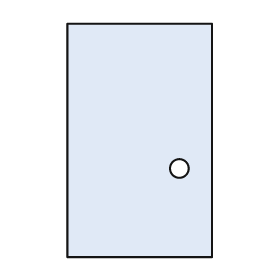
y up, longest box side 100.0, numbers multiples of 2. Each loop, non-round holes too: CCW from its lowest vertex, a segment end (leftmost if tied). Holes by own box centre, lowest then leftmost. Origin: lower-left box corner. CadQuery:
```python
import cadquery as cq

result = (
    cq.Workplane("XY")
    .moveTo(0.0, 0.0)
    .lineTo(62.0, 0.0)
    .lineTo(62.0, 100.0)
    .lineTo(0.0, 100.0)
    .close()
    .moveTo(48.0, 38.0)
    .circle(4.0)
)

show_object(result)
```